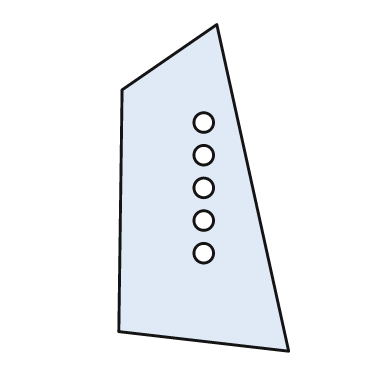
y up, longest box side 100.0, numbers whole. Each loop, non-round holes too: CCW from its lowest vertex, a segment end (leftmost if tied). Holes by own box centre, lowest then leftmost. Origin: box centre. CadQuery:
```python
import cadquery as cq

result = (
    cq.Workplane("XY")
    .moveTo(26.0, -50.0)
    .lineTo(4.0, 50.0)
    .lineTo(-25.0, 30.0)
    .lineTo(-26.0, -44.0)
    .close()
    .moveTo(0.0, -20.0)
    .circle(3.0)
    .moveTo(0.0, -10.0)
    .circle(3.0)
    .moveTo(0.0, 0.0)
    .circle(3.0)
    .moveTo(0.0, 10.0)
    .circle(3.0)
    .moveTo(0.0, 20.0)
    .circle(3.0)
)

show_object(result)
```